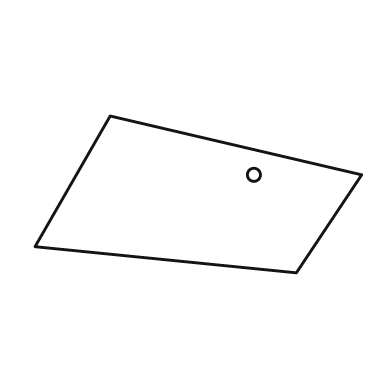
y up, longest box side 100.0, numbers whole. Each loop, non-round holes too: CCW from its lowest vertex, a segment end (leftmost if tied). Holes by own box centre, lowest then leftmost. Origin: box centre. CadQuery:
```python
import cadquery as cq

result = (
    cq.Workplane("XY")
    .moveTo(30.0, -24.0)
    .lineTo(50.0, 6.0)
    .lineTo(-27.0, 24.0)
    .lineTo(-50.0, -16.0)
    .close()
    .moveTo(17.0, 6.0)
    .circle(2.0)
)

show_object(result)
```